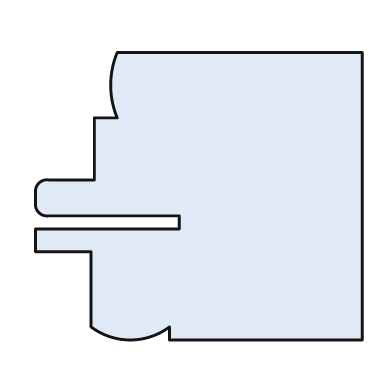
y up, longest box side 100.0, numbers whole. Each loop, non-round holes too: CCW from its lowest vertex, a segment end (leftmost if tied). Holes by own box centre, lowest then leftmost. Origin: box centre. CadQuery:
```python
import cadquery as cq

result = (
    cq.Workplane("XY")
    .moveTo(-9.0, -44.0)
    .lineTo(50.0, -44.0)
    .lineTo(50.0, 44.0)
    .lineTo(-25.0, 44.0)
    .threePointArc((-27.0, 34.0), (-25.0, 24.0))
    .lineTo(-32.0, 24.0)
    .lineTo(-32.0, 5.0)
    .lineTo(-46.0, 5.0)
    .threePointArc((-49.0, 4.0), (-50.0, 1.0))
    .lineTo(-50.0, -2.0)
    .threePointArc((-49.0, -5.0), (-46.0, -6.0))
    .lineTo(-6.0, -6.0)
    .lineTo(-6.0, -10.0)
    .lineTo(-50.0, -10.0)
    .lineTo(-50.0, -17.0)
    .lineTo(-33.0, -17.0)
    .lineTo(-33.0, -40.0)
    .threePointArc((-21.0, -44.0), (-9.0, -40.0))
    .close()
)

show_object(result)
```